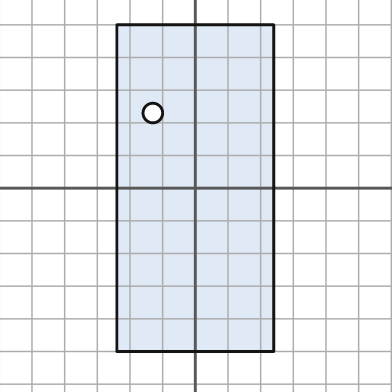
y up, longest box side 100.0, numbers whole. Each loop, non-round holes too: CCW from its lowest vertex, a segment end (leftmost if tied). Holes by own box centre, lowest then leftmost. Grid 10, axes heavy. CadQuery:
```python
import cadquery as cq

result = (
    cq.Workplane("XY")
    .moveTo(-24.0, -50.0)
    .lineTo(24.0, -50.0)
    .lineTo(24.0, 50.0)
    .lineTo(-24.0, 50.0)
    .close()
    .moveTo(-13.0, 23.0)
    .circle(3.0)
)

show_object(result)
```